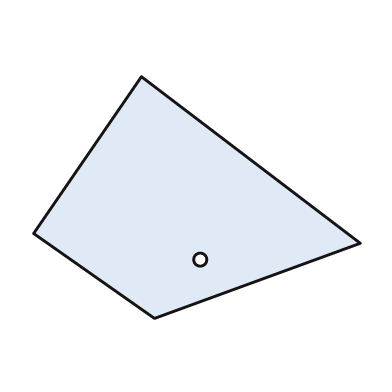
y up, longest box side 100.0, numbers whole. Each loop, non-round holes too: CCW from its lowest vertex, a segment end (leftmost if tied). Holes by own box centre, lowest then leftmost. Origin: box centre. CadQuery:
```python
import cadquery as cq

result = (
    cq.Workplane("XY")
    .moveTo(-13.0, -37.0)
    .lineTo(50.0, -14.0)
    .lineTo(-17.0, 37.0)
    .lineTo(-50.0, -11.0)
    .close()
    .moveTo(1.0, -19.0)
    .circle(2.0)
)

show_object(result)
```